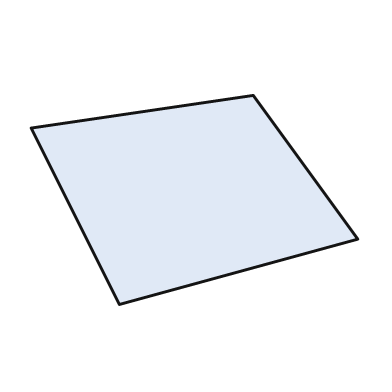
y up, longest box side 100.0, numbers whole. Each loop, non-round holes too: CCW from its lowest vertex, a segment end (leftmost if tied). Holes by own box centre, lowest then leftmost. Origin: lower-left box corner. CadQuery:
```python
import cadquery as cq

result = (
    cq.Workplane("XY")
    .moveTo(27.0, 0.0)
    .lineTo(100.0, 20.0)
    .lineTo(68.0, 64.0)
    .lineTo(0.0, 54.0)
    .close()
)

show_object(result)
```